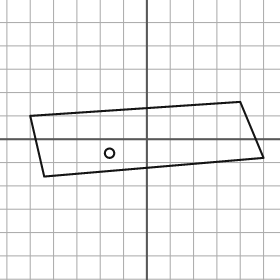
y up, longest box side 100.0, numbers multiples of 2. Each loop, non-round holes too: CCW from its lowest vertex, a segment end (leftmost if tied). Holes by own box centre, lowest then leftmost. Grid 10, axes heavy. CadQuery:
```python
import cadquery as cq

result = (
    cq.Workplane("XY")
    .moveTo(-44.0, -16.0)
    .lineTo(50.0, -8.0)
    .lineTo(40.0, 16.0)
    .lineTo(-50.0, 10.0)
    .close()
    .moveTo(-16.0, -6.0)
    .circle(2.0)
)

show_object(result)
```